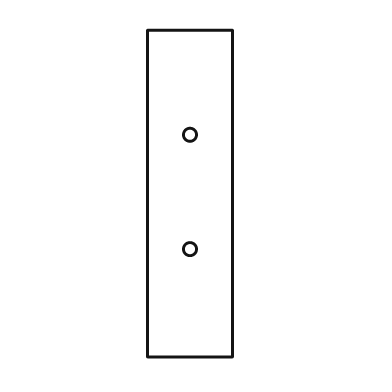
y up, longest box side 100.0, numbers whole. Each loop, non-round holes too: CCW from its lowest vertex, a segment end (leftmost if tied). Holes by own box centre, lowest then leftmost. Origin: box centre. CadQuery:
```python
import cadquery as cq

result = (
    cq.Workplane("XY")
    .moveTo(-13.0, -50.0)
    .lineTo(13.0, -50.0)
    .lineTo(13.0, 50.0)
    .lineTo(-13.0, 50.0)
    .close()
    .moveTo(0.0, -17.0)
    .circle(2.0)
    .moveTo(0.0, 18.0)
    .circle(2.0)
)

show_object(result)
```